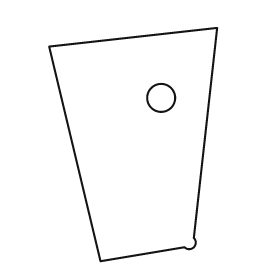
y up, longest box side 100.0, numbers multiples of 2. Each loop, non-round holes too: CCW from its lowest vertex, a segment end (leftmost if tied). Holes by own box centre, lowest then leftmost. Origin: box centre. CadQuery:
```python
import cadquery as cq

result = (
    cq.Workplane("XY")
    .moveTo(-14.0, -50.0)
    .lineTo(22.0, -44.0)
    .threePointArc((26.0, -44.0), (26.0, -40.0))
    .lineTo(36.0, 50.0)
    .lineTo(-36.0, 42.0)
    .close()
    .moveTo(12.0, 20.0)
    .circle(6.0)
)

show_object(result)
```